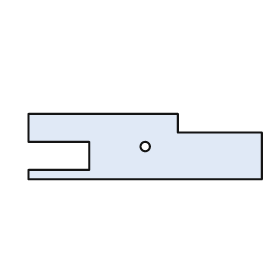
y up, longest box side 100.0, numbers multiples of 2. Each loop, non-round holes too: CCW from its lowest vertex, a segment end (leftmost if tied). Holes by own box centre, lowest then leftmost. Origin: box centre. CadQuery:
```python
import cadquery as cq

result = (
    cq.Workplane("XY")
    .moveTo(-50.0, -14.0)
    .lineTo(50.0, -14.0)
    .lineTo(50.0, 6.0)
    .lineTo(14.0, 6.0)
    .lineTo(14.0, 14.0)
    .lineTo(-50.0, 14.0)
    .lineTo(-50.0, 2.0)
    .lineTo(-24.0, 2.0)
    .lineTo(-24.0, -10.0)
    .lineTo(-50.0, -10.0)
    .close()
    .moveTo(0.0, 0.0)
    .circle(2.0)
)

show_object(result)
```